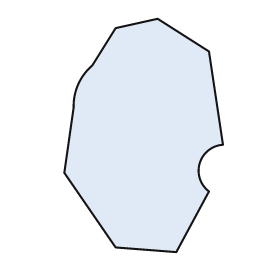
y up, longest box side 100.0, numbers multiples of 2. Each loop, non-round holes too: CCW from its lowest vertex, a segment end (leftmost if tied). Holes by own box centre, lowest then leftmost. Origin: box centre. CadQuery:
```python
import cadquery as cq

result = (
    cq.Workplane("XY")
    .moveTo(14.0, -50.0)
    .lineTo(28.0, -24.0)
    .threePointArc((24.0, -12.0), (34.0, -4.0))
    .lineTo(28.0, 36.0)
    .lineTo(6.0, 50.0)
    .lineTo(-12.0, 46.0)
    .lineTo(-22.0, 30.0)
    .threePointArc((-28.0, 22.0), (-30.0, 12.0))
    .lineTo(-34.0, -16.0)
    .lineTo(-12.0, -48.0)
    .close()
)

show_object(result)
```